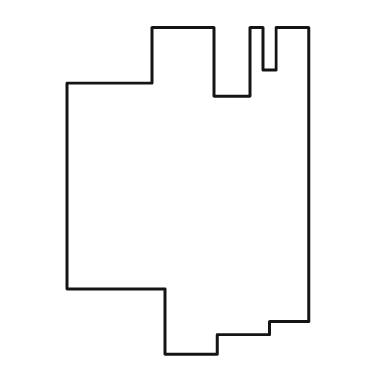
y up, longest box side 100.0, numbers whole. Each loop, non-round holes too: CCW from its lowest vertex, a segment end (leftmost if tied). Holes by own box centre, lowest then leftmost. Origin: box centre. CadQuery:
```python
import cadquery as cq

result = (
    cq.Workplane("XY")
    .moveTo(-7.0, -50.0)
    .lineTo(9.0, -50.0)
    .lineTo(9.0, -44.0)
    .lineTo(25.0, -44.0)
    .lineTo(25.0, -40.0)
    .lineTo(37.0, -40.0)
    .lineTo(37.0, 50.0)
    .lineTo(27.0, 50.0)
    .lineTo(27.0, 37.0)
    .lineTo(23.0, 37.0)
    .lineTo(23.0, 50.0)
    .lineTo(19.0, 50.0)
    .lineTo(19.0, 29.0)
    .lineTo(8.0, 29.0)
    .lineTo(8.0, 50.0)
    .lineTo(-11.0, 50.0)
    .lineTo(-11.0, 33.0)
    .lineTo(-37.0, 33.0)
    .lineTo(-37.0, -30.0)
    .lineTo(-7.0, -30.0)
    .close()
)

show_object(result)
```